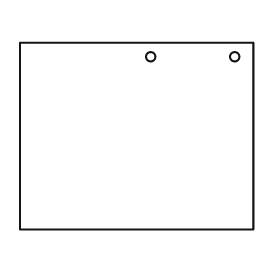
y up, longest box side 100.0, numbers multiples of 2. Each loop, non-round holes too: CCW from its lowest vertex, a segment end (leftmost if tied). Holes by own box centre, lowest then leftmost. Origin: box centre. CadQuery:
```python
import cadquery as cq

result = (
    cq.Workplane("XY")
    .moveTo(-50.0, -40.0)
    .lineTo(50.0, -40.0)
    .lineTo(50.0, 40.0)
    .lineTo(-50.0, 40.0)
    .close()
    .moveTo(6.0, 34.0)
    .circle(2.0)
    .moveTo(42.0, 34.0)
    .circle(2.0)
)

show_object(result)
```